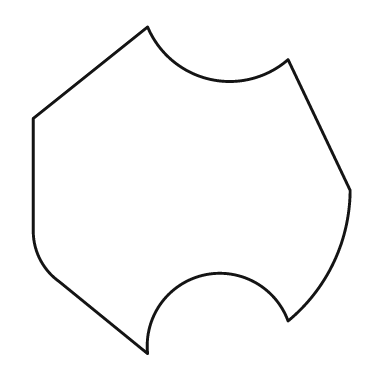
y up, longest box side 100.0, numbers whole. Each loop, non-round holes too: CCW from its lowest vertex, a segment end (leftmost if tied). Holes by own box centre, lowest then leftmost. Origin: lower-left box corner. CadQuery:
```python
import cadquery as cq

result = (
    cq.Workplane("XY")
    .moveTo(35.0, 0.0)
    .threePointArc((52.0, 24.0), (78.0, 10.0))
    .threePointArc((92.0, 28.0), (97.0, 50.0))
    .lineTo(78.0, 90.0)
    .threePointArc((54.0, 84.0), (35.0, 100.0))
    .lineTo(0.0, 72.0)
    .lineTo(0.0, 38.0)
    .threePointArc((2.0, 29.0), (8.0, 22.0))
    .close()
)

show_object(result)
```